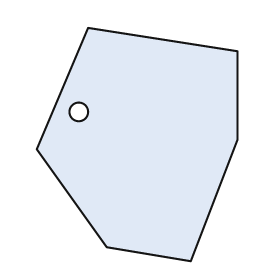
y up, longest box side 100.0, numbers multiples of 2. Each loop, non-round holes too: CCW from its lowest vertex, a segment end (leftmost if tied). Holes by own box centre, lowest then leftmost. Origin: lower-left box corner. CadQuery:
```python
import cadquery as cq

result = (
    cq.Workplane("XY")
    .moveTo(66.0, 0.0)
    .lineTo(86.0, 52.0)
    .lineTo(86.0, 90.0)
    .lineTo(22.0, 100.0)
    .lineTo(0.0, 48.0)
    .lineTo(30.0, 6.0)
    .close()
    .moveTo(18.0, 64.0)
    .circle(4.0)
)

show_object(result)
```